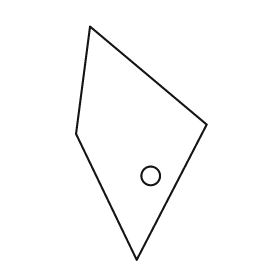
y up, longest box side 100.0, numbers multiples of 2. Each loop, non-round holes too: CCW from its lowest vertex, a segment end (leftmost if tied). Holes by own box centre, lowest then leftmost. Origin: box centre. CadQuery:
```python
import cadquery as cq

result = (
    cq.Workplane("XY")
    .moveTo(-2.0, -50.0)
    .lineTo(28.0, 8.0)
    .lineTo(-22.0, 50.0)
    .lineTo(-28.0, 4.0)
    .close()
    .moveTo(4.0, -14.0)
    .circle(4.0)
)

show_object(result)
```